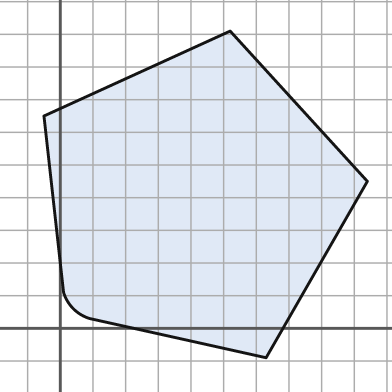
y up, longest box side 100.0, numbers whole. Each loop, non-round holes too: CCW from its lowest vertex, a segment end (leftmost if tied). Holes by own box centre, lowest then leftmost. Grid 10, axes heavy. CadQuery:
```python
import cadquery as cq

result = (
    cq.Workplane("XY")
    .moveTo(63.0, -9.0)
    .lineTo(94.0, 45.0)
    .lineTo(52.0, 91.0)
    .lineTo(-5.0, 65.0)
    .lineTo(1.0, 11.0)
    .threePointArc((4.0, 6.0), (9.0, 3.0))
    .close()
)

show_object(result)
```